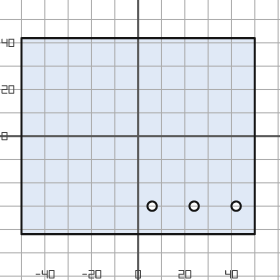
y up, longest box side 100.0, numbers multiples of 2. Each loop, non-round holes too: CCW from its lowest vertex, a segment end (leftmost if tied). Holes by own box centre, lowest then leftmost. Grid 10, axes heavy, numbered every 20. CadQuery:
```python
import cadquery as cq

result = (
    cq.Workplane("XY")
    .moveTo(-50.0, -42.0)
    .lineTo(50.0, -42.0)
    .lineTo(50.0, 42.0)
    .lineTo(-50.0, 42.0)
    .close()
    .moveTo(6.0, -30.0)
    .circle(2.0)
    .moveTo(24.0, -30.0)
    .circle(2.0)
    .moveTo(42.0, -30.0)
    .circle(2.0)
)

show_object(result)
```